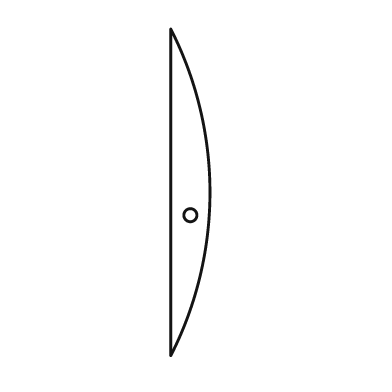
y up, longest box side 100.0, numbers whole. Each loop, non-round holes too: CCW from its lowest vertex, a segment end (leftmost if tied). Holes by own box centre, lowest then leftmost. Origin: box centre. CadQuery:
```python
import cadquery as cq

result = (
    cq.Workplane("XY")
    .moveTo(-6.0, -50.0)
    .threePointArc((6.0, 0.0), (-6.0, 50.0))
    .close()
    .moveTo(0.0, -7.0)
    .circle(2.0)
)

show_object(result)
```